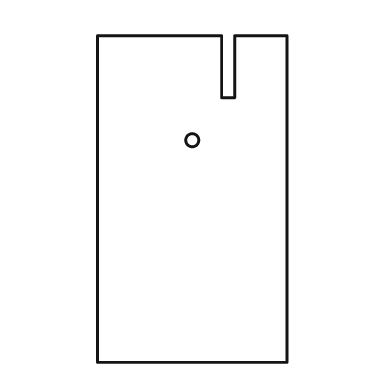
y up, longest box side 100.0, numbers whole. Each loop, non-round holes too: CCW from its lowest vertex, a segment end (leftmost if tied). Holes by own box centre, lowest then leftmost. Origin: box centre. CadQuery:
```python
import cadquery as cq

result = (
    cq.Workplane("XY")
    .moveTo(-29.0, -50.0)
    .lineTo(29.0, -50.0)
    .lineTo(29.0, 50.0)
    .lineTo(13.0, 50.0)
    .lineTo(13.0, 31.0)
    .lineTo(9.0, 31.0)
    .lineTo(9.0, 50.0)
    .lineTo(-29.0, 50.0)
    .close()
    .moveTo(0.0, 18.0)
    .circle(2.0)
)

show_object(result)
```